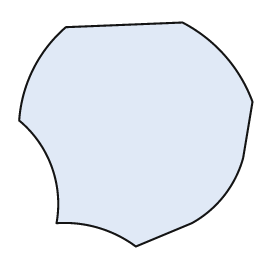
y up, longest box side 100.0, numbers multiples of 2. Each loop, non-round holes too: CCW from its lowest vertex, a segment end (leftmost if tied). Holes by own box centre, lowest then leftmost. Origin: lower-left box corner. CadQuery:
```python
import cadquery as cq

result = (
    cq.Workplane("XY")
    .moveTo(50.0, 0.0)
    .lineTo(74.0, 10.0)
    .threePointArc((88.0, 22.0), (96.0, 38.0))
    .lineTo(100.0, 62.0)
    .threePointArc((88.0, 82.0), (70.0, 96.0))
    .lineTo(20.0, 94.0)
    .threePointArc((6.0, 76.0), (0.0, 54.0))
    .threePointArc((14.0, 34.0), (16.0, 10.0))
    .threePointArc((34.0, 8.0), (50.0, 0.0))
    .close()
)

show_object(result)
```